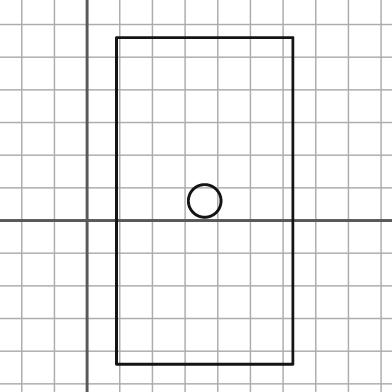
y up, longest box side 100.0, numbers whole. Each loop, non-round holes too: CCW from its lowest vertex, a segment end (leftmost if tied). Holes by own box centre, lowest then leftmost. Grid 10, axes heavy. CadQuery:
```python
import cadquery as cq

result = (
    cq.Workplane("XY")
    .moveTo(9.0, -44.0)
    .lineTo(63.0, -44.0)
    .lineTo(63.0, 56.0)
    .lineTo(9.0, 56.0)
    .close()
    .moveTo(36.0, 6.0)
    .circle(5.0)
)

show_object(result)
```